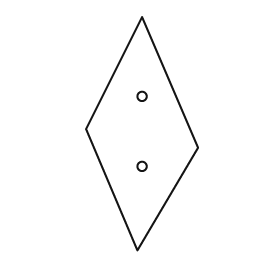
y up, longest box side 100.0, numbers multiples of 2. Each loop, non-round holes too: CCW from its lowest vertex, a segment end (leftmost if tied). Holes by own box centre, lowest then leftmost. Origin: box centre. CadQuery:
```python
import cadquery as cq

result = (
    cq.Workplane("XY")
    .moveTo(-2.0, -50.0)
    .lineTo(24.0, -6.0)
    .lineTo(0.0, 50.0)
    .lineTo(-24.0, 2.0)
    .close()
    .moveTo(0.0, -14.0)
    .circle(2.0)
    .moveTo(0.0, 16.0)
    .circle(2.0)
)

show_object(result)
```